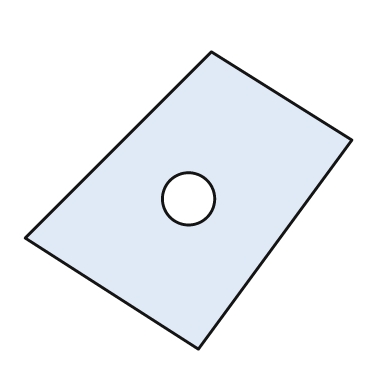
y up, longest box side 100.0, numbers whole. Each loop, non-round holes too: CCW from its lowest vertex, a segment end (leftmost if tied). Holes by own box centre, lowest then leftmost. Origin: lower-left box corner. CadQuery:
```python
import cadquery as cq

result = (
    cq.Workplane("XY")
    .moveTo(53.0, 0.0)
    .lineTo(100.0, 64.0)
    .lineTo(57.0, 91.0)
    .lineTo(0.0, 34.0)
    .close()
    .moveTo(50.0, 46.0)
    .circle(8.0)
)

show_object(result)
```